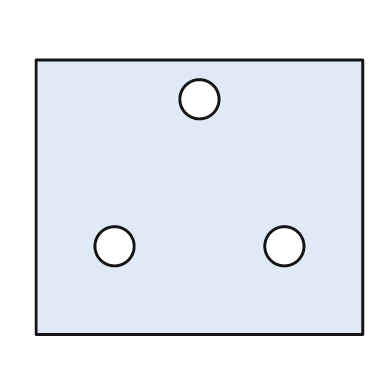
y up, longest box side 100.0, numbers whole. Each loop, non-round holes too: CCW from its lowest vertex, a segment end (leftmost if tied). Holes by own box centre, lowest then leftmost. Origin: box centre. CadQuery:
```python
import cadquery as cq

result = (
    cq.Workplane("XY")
    .moveTo(-50.0, -42.0)
    .lineTo(50.0, -42.0)
    .lineTo(50.0, 42.0)
    .lineTo(-50.0, 42.0)
    .close()
    .moveTo(-26.0, -15.0)
    .circle(6.0)
    .moveTo(26.0, -15.0)
    .circle(6.0)
    .moveTo(0.0, 30.0)
    .circle(6.0)
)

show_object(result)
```